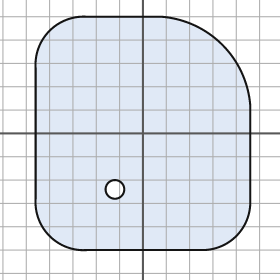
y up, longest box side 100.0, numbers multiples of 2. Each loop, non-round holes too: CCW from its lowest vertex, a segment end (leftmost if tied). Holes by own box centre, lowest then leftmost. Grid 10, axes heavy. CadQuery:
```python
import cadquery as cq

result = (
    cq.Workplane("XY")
    .moveTo(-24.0, -50.0)
    .lineTo(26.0, -50.0)
    .threePointArc((40.0, -44.0), (46.0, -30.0))
    .lineTo(46.0, 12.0)
    .threePointArc((34.0, 38.0), (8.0, 50.0))
    .lineTo(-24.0, 50.0)
    .threePointArc((-40.0, 44.0), (-46.0, 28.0))
    .lineTo(-46.0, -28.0)
    .threePointArc((-40.0, -44.0), (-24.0, -50.0))
    .close()
    .moveTo(-12.0, -24.0)
    .circle(4.0)
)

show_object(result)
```